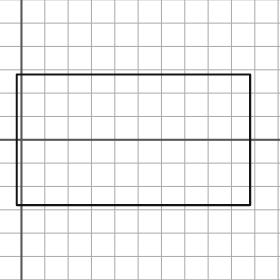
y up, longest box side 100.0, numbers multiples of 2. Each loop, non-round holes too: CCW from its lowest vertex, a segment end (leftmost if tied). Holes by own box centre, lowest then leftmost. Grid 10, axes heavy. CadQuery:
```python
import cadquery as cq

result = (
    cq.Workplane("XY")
    .moveTo(-2.0, -28.0)
    .lineTo(98.0, -28.0)
    .lineTo(98.0, 28.0)
    .lineTo(-2.0, 28.0)
    .close()
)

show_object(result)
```